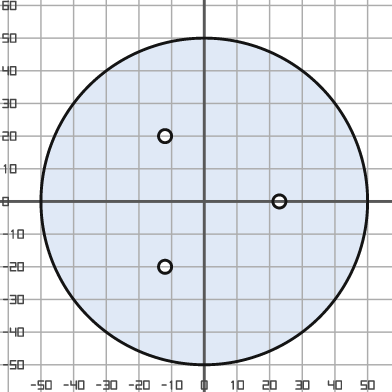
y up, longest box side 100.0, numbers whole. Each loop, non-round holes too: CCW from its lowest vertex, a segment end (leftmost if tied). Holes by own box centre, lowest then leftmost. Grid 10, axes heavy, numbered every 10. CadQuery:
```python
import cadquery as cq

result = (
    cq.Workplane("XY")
    .moveTo(0.0, 0.0)
    .circle(50.0)
    .moveTo(-12.0, -20.0)
    .circle(2.0)
    .moveTo(23.0, 0.0)
    .circle(2.0)
    .moveTo(-12.0, 20.0)
    .circle(2.0)
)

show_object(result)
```